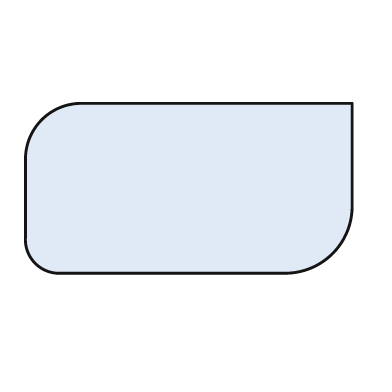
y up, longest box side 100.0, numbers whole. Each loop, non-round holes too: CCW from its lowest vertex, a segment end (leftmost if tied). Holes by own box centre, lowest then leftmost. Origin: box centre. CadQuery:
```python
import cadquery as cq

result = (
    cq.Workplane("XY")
    .moveTo(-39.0, -26.0)
    .lineTo(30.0, -26.0)
    .threePointArc((44.0, -20.0), (50.0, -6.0))
    .lineTo(50.0, 26.0)
    .lineTo(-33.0, 26.0)
    .threePointArc((-45.0, 21.0), (-50.0, 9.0))
    .lineTo(-50.0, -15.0)
    .threePointArc((-47.0, -23.0), (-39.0, -26.0))
    .close()
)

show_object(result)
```